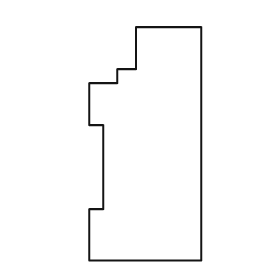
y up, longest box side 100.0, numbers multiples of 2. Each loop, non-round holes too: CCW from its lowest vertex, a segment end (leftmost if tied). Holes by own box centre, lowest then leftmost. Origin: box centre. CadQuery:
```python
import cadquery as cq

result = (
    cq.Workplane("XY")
    .moveTo(-24.0, -50.0)
    .lineTo(24.0, -50.0)
    .lineTo(24.0, 50.0)
    .lineTo(-4.0, 50.0)
    .lineTo(-4.0, 32.0)
    .lineTo(-12.0, 32.0)
    .lineTo(-12.0, 26.0)
    .lineTo(-24.0, 26.0)
    .lineTo(-24.0, 8.0)
    .lineTo(-18.0, 8.0)
    .lineTo(-18.0, -28.0)
    .lineTo(-24.0, -28.0)
    .close()
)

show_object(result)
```